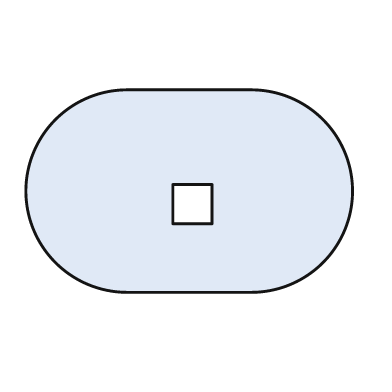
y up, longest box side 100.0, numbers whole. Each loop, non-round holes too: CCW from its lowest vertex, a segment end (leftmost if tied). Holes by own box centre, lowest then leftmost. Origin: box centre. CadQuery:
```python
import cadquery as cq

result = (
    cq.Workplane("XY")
    .moveTo(-19.0, -31.0)
    .lineTo(19.0, -31.0)
    .threePointArc((50.0, 0.0), (19.0, 31.0))
    .lineTo(-19.0, 31.0)
    .threePointArc((-50.0, 0.0), (-19.0, -31.0))
    .close()
    .moveTo(-5.0, -10.0)
    .lineTo(7.0, -10.0)
    .lineTo(7.0, 2.0)
    .lineTo(-5.0, 2.0)
    .close()
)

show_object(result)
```